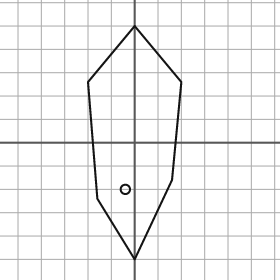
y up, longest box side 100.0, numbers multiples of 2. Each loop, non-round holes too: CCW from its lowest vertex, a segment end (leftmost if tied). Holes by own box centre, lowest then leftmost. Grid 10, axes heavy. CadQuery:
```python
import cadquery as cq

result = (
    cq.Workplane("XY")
    .moveTo(0.0, -50.0)
    .lineTo(16.0, -16.0)
    .lineTo(20.0, 26.0)
    .lineTo(0.0, 50.0)
    .lineTo(-20.0, 26.0)
    .lineTo(-16.0, -24.0)
    .close()
    .moveTo(-4.0, -20.0)
    .circle(2.0)
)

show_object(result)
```